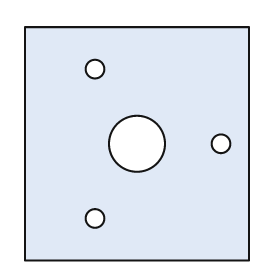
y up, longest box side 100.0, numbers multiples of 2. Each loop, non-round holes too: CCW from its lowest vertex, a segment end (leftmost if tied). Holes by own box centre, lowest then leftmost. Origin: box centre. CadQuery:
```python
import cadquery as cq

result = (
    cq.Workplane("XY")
    .moveTo(-48.0, -50.0)
    .lineTo(48.0, -50.0)
    .lineTo(48.0, 50.0)
    .lineTo(-48.0, 50.0)
    .close()
    .moveTo(-18.0, -32.0)
    .circle(4.0)
    .moveTo(0.0, 0.0)
    .circle(12.0)
    .moveTo(36.0, 0.0)
    .circle(4.0)
    .moveTo(-18.0, 32.0)
    .circle(4.0)
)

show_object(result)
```